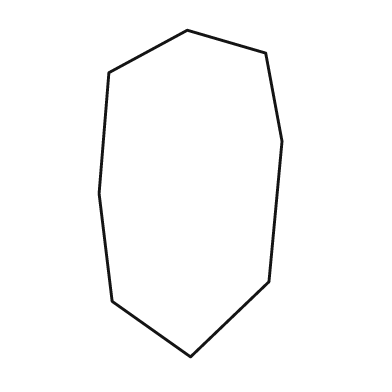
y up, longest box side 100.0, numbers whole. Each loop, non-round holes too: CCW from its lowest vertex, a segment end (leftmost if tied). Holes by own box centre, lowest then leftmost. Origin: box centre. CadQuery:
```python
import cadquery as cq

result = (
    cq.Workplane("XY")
    .moveTo(0.0, -50.0)
    .lineTo(24.0, -27.0)
    .lineTo(28.0, 16.0)
    .lineTo(23.0, 43.0)
    .lineTo(-1.0, 50.0)
    .lineTo(-25.0, 37.0)
    .lineTo(-28.0, 0.0)
    .lineTo(-24.0, -33.0)
    .close()
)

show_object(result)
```